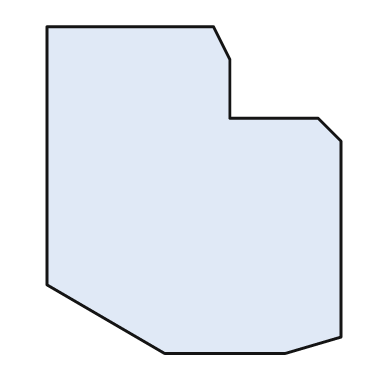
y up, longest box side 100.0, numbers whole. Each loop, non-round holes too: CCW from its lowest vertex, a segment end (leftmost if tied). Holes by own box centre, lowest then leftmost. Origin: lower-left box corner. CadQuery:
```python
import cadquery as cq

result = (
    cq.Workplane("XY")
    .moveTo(36.0, 0.0)
    .lineTo(73.0, 0.0)
    .lineTo(90.0, 5.0)
    .lineTo(90.0, 65.0)
    .lineTo(83.0, 72.0)
    .lineTo(56.0, 72.0)
    .lineTo(56.0, 90.0)
    .lineTo(51.0, 100.0)
    .lineTo(0.0, 100.0)
    .lineTo(0.0, 21.0)
    .close()
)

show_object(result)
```